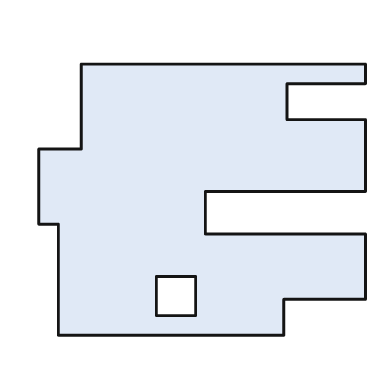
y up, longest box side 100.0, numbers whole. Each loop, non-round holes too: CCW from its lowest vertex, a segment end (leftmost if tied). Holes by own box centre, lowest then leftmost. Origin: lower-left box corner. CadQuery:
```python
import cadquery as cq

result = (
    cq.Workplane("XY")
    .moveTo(6.0, 0.0)
    .lineTo(75.0, 0.0)
    .lineTo(75.0, 11.0)
    .lineTo(100.0, 11.0)
    .lineTo(100.0, 31.0)
    .lineTo(51.0, 31.0)
    .lineTo(51.0, 44.0)
    .lineTo(100.0, 44.0)
    .lineTo(100.0, 66.0)
    .lineTo(76.0, 66.0)
    .lineTo(76.0, 77.0)
    .lineTo(100.0, 77.0)
    .lineTo(100.0, 83.0)
    .lineTo(13.0, 83.0)
    .lineTo(13.0, 57.0)
    .lineTo(0.0, 57.0)
    .lineTo(0.0, 34.0)
    .lineTo(6.0, 34.0)
    .close()
    .moveTo(36.0, 6.0)
    .lineTo(48.0, 6.0)
    .lineTo(48.0, 18.0)
    .lineTo(36.0, 18.0)
    .close()
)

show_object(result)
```